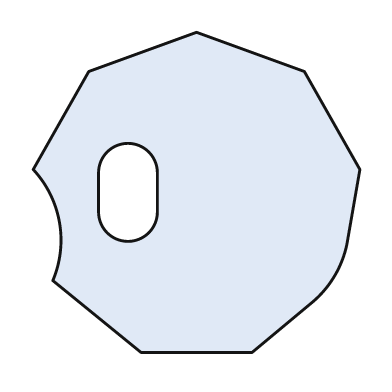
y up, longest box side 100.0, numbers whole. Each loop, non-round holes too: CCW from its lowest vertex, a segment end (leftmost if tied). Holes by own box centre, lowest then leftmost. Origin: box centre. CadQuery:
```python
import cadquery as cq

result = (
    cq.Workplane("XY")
    .moveTo(-17.0, -49.0)
    .lineTo(17.0, -49.0)
    .lineTo(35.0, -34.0)
    .threePointArc((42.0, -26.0), (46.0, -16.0))
    .lineTo(50.0, 7.0)
    .lineTo(33.0, 37.0)
    .lineTo(0.0, 49.0)
    .lineTo(-33.0, 37.0)
    .lineTo(-50.0, 7.0)
    .threePointArc((-42.0, -9.0), (-44.0, -27.0))
    .close()
    .moveTo(-30.0, -6.0)
    .threePointArc((-21.0, -15.0), (-12.0, -6.0))
    .lineTo(-12.0, 6.0)
    .threePointArc((-21.0, 15.0), (-30.0, 6.0))
    .close()
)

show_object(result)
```